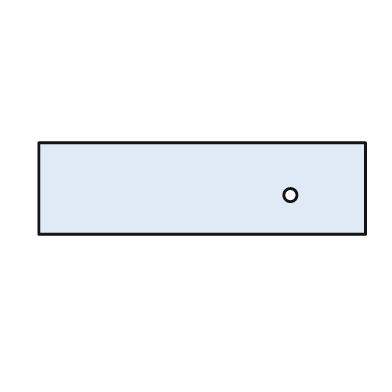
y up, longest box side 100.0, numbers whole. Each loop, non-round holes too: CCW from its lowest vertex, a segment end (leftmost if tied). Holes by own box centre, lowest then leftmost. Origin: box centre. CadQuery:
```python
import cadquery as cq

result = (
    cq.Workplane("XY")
    .moveTo(-50.0, -14.0)
    .lineTo(50.0, -14.0)
    .lineTo(50.0, 14.0)
    .lineTo(-50.0, 14.0)
    .close()
    .moveTo(27.0, -2.0)
    .circle(2.0)
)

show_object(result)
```